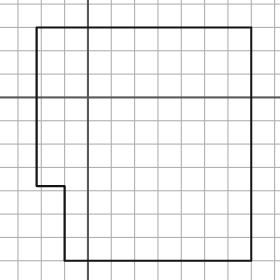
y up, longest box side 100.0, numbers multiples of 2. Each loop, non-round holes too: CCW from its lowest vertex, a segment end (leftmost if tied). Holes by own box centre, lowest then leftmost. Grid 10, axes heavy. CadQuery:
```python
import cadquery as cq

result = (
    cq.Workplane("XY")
    .moveTo(-10.0, -70.0)
    .lineTo(70.0, -70.0)
    .lineTo(70.0, 30.0)
    .lineTo(-22.0, 30.0)
    .lineTo(-22.0, -38.0)
    .lineTo(-10.0, -38.0)
    .close()
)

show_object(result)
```